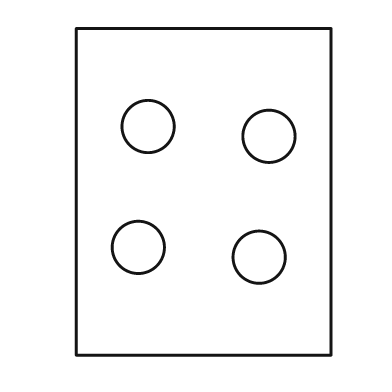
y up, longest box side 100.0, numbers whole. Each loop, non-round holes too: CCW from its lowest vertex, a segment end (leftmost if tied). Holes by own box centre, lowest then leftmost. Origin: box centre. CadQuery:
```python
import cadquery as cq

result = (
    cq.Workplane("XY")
    .moveTo(-39.0, -50.0)
    .lineTo(39.0, -50.0)
    .lineTo(39.0, 50.0)
    .lineTo(-39.0, 50.0)
    .close()
    .moveTo(17.0, -20.0)
    .circle(8.0)
    .moveTo(-20.0, -17.0)
    .circle(8.0)
    .moveTo(20.0, 17.0)
    .circle(8.0)
    .moveTo(-17.0, 20.0)
    .circle(8.0)
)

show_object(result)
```